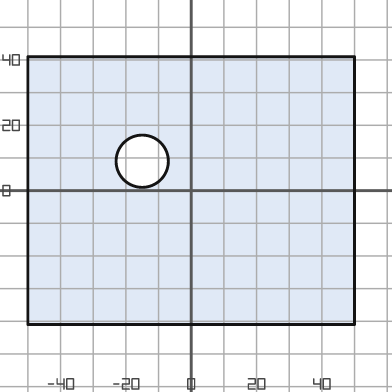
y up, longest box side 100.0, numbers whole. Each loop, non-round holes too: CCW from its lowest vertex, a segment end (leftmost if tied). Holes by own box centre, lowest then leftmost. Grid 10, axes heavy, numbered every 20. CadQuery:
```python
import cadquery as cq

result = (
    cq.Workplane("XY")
    .moveTo(-50.0, -41.0)
    .lineTo(50.0, -41.0)
    .lineTo(50.0, 41.0)
    .lineTo(-50.0, 41.0)
    .close()
    .moveTo(-15.0, 9.0)
    .circle(8.0)
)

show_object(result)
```